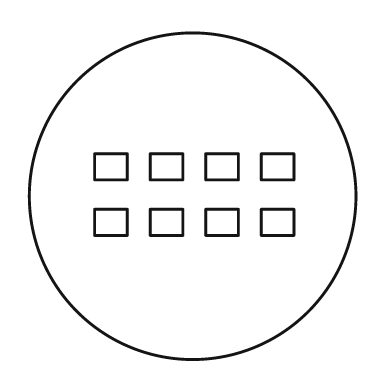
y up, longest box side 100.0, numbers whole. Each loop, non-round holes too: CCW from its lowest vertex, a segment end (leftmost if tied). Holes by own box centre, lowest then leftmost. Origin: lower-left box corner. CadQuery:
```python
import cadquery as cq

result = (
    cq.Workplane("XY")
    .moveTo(50.0, 50.0)
    .circle(50.0)
    .moveTo(20.0, 38.0)
    .lineTo(30.0, 38.0)
    .lineTo(30.0, 46.0)
    .lineTo(20.0, 46.0)
    .close()
    .moveTo(37.0, 38.0)
    .lineTo(47.0, 38.0)
    .lineTo(47.0, 46.0)
    .lineTo(37.0, 46.0)
    .close()
    .moveTo(54.0, 38.0)
    .lineTo(64.0, 38.0)
    .lineTo(64.0, 46.0)
    .lineTo(54.0, 46.0)
    .close()
    .moveTo(71.0, 38.0)
    .lineTo(81.0, 38.0)
    .lineTo(81.0, 46.0)
    .lineTo(71.0, 46.0)
    .close()
    .moveTo(20.0, 55.0)
    .lineTo(30.0, 55.0)
    .lineTo(30.0, 63.0)
    .lineTo(20.0, 63.0)
    .close()
    .moveTo(37.0, 55.0)
    .lineTo(47.0, 55.0)
    .lineTo(47.0, 63.0)
    .lineTo(37.0, 63.0)
    .close()
    .moveTo(54.0, 55.0)
    .lineTo(64.0, 55.0)
    .lineTo(64.0, 63.0)
    .lineTo(54.0, 63.0)
    .close()
    .moveTo(71.0, 55.0)
    .lineTo(81.0, 55.0)
    .lineTo(81.0, 63.0)
    .lineTo(71.0, 63.0)
    .close()
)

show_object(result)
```